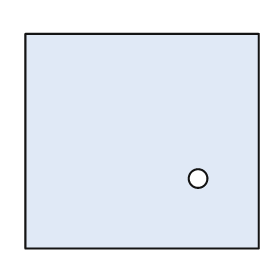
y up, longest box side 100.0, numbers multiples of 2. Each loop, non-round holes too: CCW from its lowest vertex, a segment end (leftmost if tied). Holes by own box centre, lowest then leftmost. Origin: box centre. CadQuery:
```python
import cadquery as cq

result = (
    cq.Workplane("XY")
    .moveTo(-50.0, -46.0)
    .lineTo(50.0, -46.0)
    .lineTo(50.0, 46.0)
    .lineTo(-50.0, 46.0)
    .close()
    .moveTo(24.0, -16.0)
    .circle(4.0)
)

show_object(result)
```